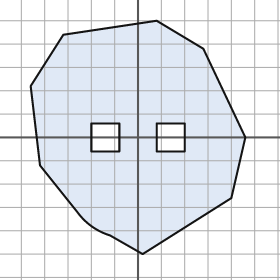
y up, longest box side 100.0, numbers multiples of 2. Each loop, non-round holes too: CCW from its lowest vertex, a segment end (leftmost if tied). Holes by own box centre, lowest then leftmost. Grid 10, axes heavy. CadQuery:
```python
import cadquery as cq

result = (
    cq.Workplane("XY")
    .moveTo(2.0, -50.0)
    .lineTo(40.0, -26.0)
    .lineTo(46.0, 0.0)
    .lineTo(28.0, 38.0)
    .lineTo(8.0, 50.0)
    .lineTo(-32.0, 44.0)
    .lineTo(-46.0, 22.0)
    .lineTo(-42.0, -12.0)
    .lineTo(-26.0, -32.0)
    .threePointArc((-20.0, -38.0), (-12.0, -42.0))
    .close()
    .moveTo(-20.0, -6.0)
    .lineTo(-8.0, -6.0)
    .lineTo(-8.0, 6.0)
    .lineTo(-20.0, 6.0)
    .close()
    .moveTo(8.0, -6.0)
    .lineTo(20.0, -6.0)
    .lineTo(20.0, 6.0)
    .lineTo(8.0, 6.0)
    .close()
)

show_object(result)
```